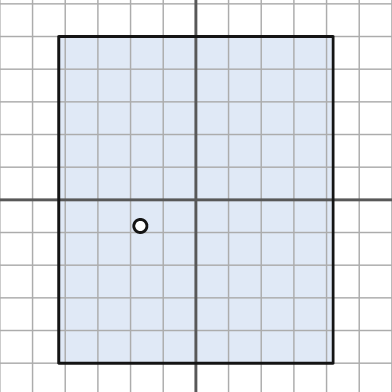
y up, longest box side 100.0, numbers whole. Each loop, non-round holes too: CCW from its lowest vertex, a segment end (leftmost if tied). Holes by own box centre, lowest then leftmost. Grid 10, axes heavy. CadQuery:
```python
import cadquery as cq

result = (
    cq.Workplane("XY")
    .moveTo(-42.0, -50.0)
    .lineTo(42.0, -50.0)
    .lineTo(42.0, 50.0)
    .lineTo(-42.0, 50.0)
    .close()
    .moveTo(-17.0, -8.0)
    .circle(2.0)
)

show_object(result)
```